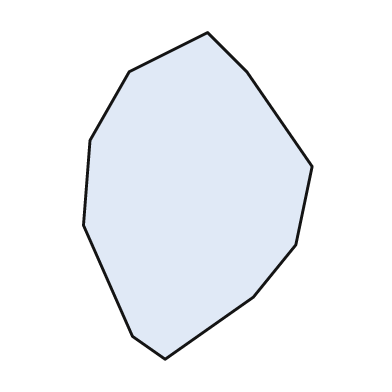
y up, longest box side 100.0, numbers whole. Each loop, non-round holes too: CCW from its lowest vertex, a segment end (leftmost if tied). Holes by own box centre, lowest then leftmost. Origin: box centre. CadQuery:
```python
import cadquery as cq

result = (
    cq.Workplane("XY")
    .moveTo(-10.0, -50.0)
    .lineTo(17.0, -31.0)
    .lineTo(30.0, -15.0)
    .lineTo(35.0, 9.0)
    .lineTo(15.0, 38.0)
    .lineTo(3.0, 50.0)
    .lineTo(-21.0, 38.0)
    .lineTo(-33.0, 17.0)
    .lineTo(-35.0, -9.0)
    .lineTo(-20.0, -43.0)
    .close()
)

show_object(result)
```